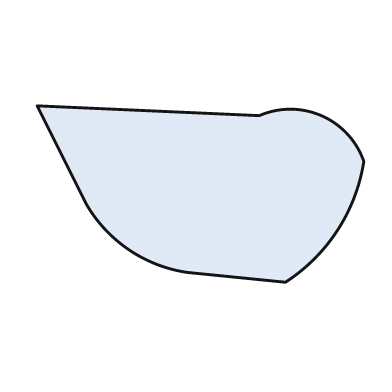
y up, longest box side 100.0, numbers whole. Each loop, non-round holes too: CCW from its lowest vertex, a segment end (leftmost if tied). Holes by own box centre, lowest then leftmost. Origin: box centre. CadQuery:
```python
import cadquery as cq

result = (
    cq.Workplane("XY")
    .moveTo(26.0, -27.0)
    .threePointArc((42.0, -11.0), (50.0, 10.0))
    .threePointArc((37.0, 24.0), (18.0, 24.0))
    .lineTo(-50.0, 27.0)
    .lineTo(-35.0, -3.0)
    .threePointArc((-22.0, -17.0), (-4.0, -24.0))
    .close()
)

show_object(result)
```